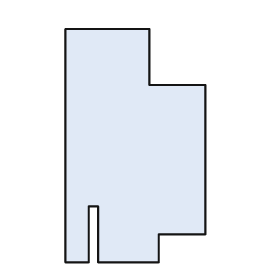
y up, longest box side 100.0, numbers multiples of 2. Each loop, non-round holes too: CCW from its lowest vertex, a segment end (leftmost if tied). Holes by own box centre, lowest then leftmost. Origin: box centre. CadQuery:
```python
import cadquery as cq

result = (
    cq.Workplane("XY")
    .moveTo(-30.0, -50.0)
    .lineTo(-20.0, -50.0)
    .lineTo(-20.0, -26.0)
    .lineTo(-16.0, -26.0)
    .lineTo(-16.0, -50.0)
    .lineTo(10.0, -50.0)
    .lineTo(10.0, -38.0)
    .lineTo(30.0, -38.0)
    .lineTo(30.0, 26.0)
    .lineTo(6.0, 26.0)
    .lineTo(6.0, 50.0)
    .lineTo(-30.0, 50.0)
    .close()
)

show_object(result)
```